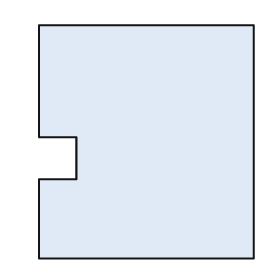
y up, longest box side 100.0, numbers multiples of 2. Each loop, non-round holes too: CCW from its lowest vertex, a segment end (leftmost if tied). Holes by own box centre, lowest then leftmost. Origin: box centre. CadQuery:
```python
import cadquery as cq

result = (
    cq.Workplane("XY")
    .moveTo(-46.0, -50.0)
    .lineTo(46.0, -50.0)
    .lineTo(46.0, 50.0)
    .lineTo(-46.0, 50.0)
    .lineTo(-46.0, 2.0)
    .lineTo(-30.0, 2.0)
    .lineTo(-30.0, -16.0)
    .lineTo(-46.0, -16.0)
    .close()
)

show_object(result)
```